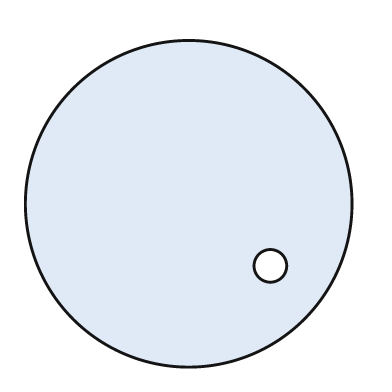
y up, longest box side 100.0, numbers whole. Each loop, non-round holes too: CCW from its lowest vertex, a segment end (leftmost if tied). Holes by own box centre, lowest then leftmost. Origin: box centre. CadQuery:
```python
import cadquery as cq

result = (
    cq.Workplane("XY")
    .moveTo(0.0, 0.0)
    .circle(50.0)
    .moveTo(25.0, -19.0)
    .circle(5.0)
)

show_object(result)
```